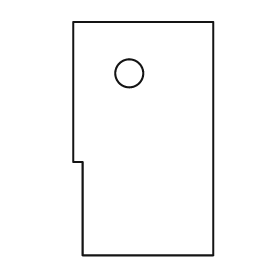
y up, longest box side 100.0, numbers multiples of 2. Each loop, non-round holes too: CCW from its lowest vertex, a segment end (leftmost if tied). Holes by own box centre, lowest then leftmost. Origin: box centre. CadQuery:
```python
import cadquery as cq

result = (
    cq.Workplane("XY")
    .moveTo(-26.0, -50.0)
    .lineTo(30.0, -50.0)
    .lineTo(30.0, 50.0)
    .lineTo(-30.0, 50.0)
    .lineTo(-30.0, -10.0)
    .lineTo(-26.0, -10.0)
    .close()
    .moveTo(-6.0, 28.0)
    .circle(6.0)
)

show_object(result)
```